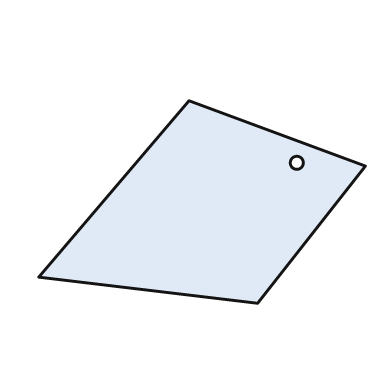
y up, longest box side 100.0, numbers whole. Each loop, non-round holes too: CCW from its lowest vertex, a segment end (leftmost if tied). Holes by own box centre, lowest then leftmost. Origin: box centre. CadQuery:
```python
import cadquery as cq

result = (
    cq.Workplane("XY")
    .moveTo(17.0, -31.0)
    .lineTo(50.0, 11.0)
    .lineTo(-4.0, 31.0)
    .lineTo(-50.0, -23.0)
    .close()
    .moveTo(29.0, 12.0)
    .circle(2.0)
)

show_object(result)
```